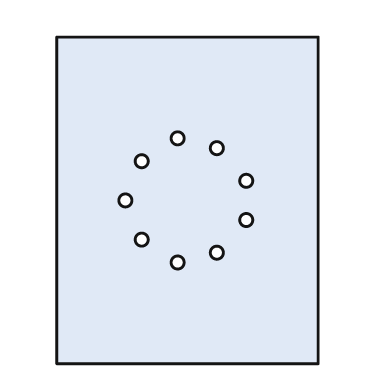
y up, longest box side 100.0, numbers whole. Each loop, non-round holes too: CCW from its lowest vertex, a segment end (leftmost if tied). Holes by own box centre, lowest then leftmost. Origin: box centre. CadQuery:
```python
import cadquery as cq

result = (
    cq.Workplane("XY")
    .moveTo(-40.0, -50.0)
    .lineTo(40.0, -50.0)
    .lineTo(40.0, 50.0)
    .lineTo(-40.0, 50.0)
    .close()
    .moveTo(-3.0, -19.0)
    .circle(2.0)
    .moveTo(9.0, -16.0)
    .circle(2.0)
    .moveTo(-14.0, -12.0)
    .circle(2.0)
    .moveTo(18.0, -6.0)
    .circle(2.0)
    .moveTo(-19.0, 0.0)
    .circle(2.0)
    .moveTo(18.0, 6.0)
    .circle(2.0)
    .moveTo(-14.0, 12.0)
    .circle(2.0)
    .moveTo(9.0, 16.0)
    .circle(2.0)
    .moveTo(-3.0, 19.0)
    .circle(2.0)
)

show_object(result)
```